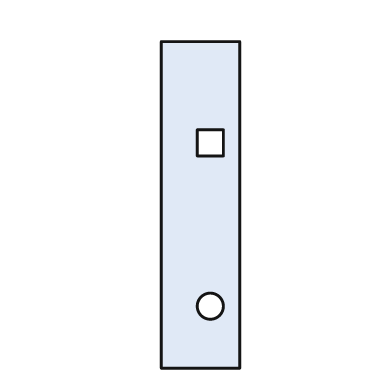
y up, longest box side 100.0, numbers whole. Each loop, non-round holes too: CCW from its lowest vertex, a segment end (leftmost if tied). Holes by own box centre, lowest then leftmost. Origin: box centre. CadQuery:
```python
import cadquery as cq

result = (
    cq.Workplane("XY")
    .moveTo(-12.0, -50.0)
    .lineTo(12.0, -50.0)
    .lineTo(12.0, 50.0)
    .lineTo(-12.0, 50.0)
    .close()
    .moveTo(3.0, -31.0)
    .circle(4.0)
    .moveTo(-1.0, 15.0)
    .lineTo(7.0, 15.0)
    .lineTo(7.0, 23.0)
    .lineTo(-1.0, 23.0)
    .close()
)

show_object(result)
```